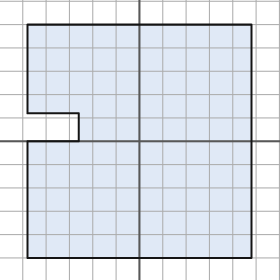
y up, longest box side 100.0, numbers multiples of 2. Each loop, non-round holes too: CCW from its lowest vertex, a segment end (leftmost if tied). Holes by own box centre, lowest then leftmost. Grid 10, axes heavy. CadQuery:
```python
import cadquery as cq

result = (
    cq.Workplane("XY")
    .moveTo(-48.0, -50.0)
    .lineTo(48.0, -50.0)
    .lineTo(48.0, 50.0)
    .lineTo(-48.0, 50.0)
    .lineTo(-48.0, 12.0)
    .lineTo(-26.0, 12.0)
    .lineTo(-26.0, 0.0)
    .lineTo(-48.0, 0.0)
    .close()
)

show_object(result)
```